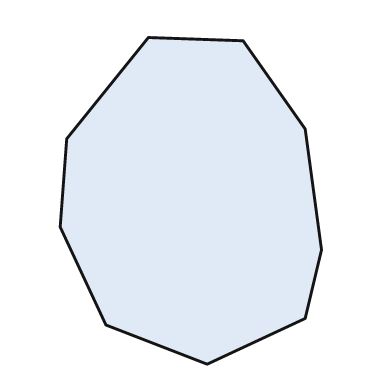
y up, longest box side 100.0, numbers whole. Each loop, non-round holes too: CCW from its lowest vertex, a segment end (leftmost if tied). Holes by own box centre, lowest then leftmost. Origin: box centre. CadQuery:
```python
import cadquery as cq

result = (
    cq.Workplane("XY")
    .moveTo(5.0, -50.0)
    .lineTo(35.0, -36.0)
    .lineTo(40.0, -15.0)
    .lineTo(35.0, 22.0)
    .lineTo(16.0, 49.0)
    .lineTo(-13.0, 50.0)
    .lineTo(-38.0, 19.0)
    .lineTo(-40.0, -8.0)
    .lineTo(-26.0, -38.0)
    .close()
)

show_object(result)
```